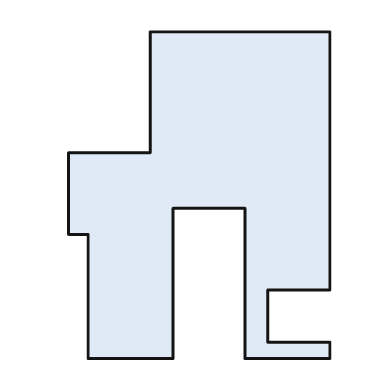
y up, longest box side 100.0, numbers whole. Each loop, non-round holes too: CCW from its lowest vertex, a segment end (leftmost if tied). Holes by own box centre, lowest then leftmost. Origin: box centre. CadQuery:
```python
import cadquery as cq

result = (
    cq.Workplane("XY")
    .moveTo(-34.0, -50.0)
    .lineTo(-8.0, -50.0)
    .lineTo(-8.0, -4.0)
    .lineTo(14.0, -4.0)
    .lineTo(14.0, -50.0)
    .lineTo(40.0, -50.0)
    .lineTo(40.0, -45.0)
    .lineTo(21.0, -45.0)
    .lineTo(21.0, -29.0)
    .lineTo(40.0, -29.0)
    .lineTo(40.0, 50.0)
    .lineTo(-15.0, 50.0)
    .lineTo(-15.0, 13.0)
    .lineTo(-40.0, 13.0)
    .lineTo(-40.0, -12.0)
    .lineTo(-34.0, -12.0)
    .close()
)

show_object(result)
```